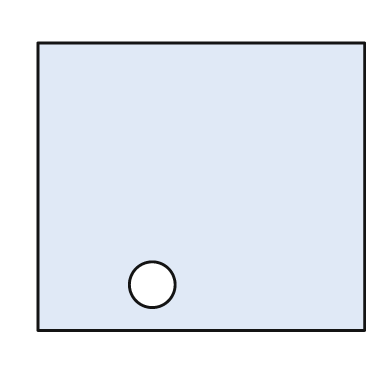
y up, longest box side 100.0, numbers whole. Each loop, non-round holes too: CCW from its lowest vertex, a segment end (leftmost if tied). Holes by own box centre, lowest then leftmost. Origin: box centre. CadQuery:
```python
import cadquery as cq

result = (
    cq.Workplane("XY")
    .moveTo(-50.0, -44.0)
    .lineTo(50.0, -44.0)
    .lineTo(50.0, 44.0)
    .lineTo(-50.0, 44.0)
    .close()
    .moveTo(-15.0, -30.0)
    .circle(7.0)
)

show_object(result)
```